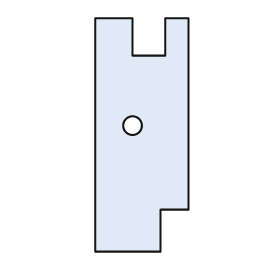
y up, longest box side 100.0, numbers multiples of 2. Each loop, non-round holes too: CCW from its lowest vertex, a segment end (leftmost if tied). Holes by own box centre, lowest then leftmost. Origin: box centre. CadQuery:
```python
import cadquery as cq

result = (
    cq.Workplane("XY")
    .moveTo(-20.0, -50.0)
    .lineTo(8.0, -50.0)
    .lineTo(8.0, -32.0)
    .lineTo(20.0, -32.0)
    .lineTo(20.0, 50.0)
    .lineTo(10.0, 50.0)
    .lineTo(10.0, 34.0)
    .lineTo(-4.0, 34.0)
    .lineTo(-4.0, 50.0)
    .lineTo(-20.0, 50.0)
    .close()
    .moveTo(-4.0, 4.0)
    .circle(4.0)
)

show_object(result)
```